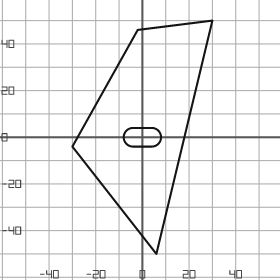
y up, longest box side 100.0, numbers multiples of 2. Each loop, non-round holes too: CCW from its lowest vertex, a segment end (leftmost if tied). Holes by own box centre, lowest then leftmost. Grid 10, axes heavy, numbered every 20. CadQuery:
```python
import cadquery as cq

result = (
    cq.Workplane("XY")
    .moveTo(6.0, -50.0)
    .lineTo(30.0, 50.0)
    .lineTo(-2.0, 46.0)
    .lineTo(-30.0, -4.0)
    .close()
    .moveTo(-4.0, -4.0)
    .lineTo(4.0, -4.0)
    .threePointArc((8.0, 0.0), (4.0, 4.0))
    .lineTo(-4.0, 4.0)
    .threePointArc((-8.0, 0.0), (-4.0, -4.0))
    .close()
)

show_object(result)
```